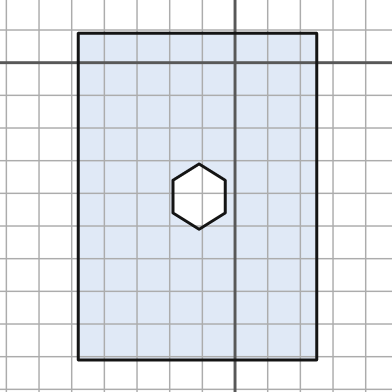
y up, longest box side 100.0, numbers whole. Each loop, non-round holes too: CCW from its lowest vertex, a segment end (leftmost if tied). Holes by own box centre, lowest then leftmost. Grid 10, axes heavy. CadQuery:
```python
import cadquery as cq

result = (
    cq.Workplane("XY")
    .moveTo(-48.0, -91.0)
    .lineTo(25.0, -91.0)
    .lineTo(25.0, 9.0)
    .lineTo(-48.0, 9.0)
    .close()
    .moveTo(-11.0, -51.0)
    .lineTo(-3.0, -46.0)
    .lineTo(-3.0, -36.0)
    .lineTo(-11.0, -31.0)
    .lineTo(-19.0, -36.0)
    .lineTo(-19.0, -46.0)
    .close()
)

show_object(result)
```